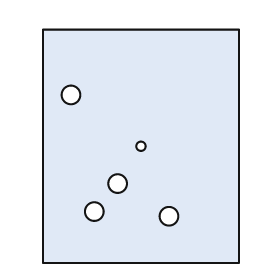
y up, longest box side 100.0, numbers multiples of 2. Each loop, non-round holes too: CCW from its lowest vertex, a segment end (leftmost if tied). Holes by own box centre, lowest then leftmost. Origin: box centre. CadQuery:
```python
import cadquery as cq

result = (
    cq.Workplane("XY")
    .moveTo(-42.0, -50.0)
    .lineTo(42.0, -50.0)
    .lineTo(42.0, 50.0)
    .lineTo(-42.0, 50.0)
    .close()
    .moveTo(12.0, -30.0)
    .circle(4.0)
    .moveTo(-20.0, -28.0)
    .circle(4.0)
    .moveTo(-10.0, -16.0)
    .circle(4.0)
    .moveTo(0.0, 0.0)
    .circle(2.0)
    .moveTo(-30.0, 22.0)
    .circle(4.0)
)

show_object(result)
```